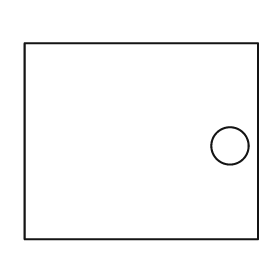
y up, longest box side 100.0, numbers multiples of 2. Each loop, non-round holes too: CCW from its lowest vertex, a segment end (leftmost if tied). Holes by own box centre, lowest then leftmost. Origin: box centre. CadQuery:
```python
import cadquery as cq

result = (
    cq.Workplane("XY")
    .moveTo(-50.0, -42.0)
    .lineTo(50.0, -42.0)
    .lineTo(50.0, 42.0)
    .lineTo(-50.0, 42.0)
    .close()
    .moveTo(38.0, -2.0)
    .circle(8.0)
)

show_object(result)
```